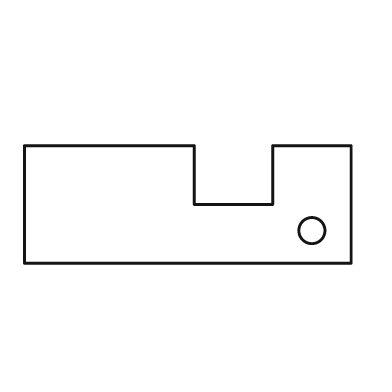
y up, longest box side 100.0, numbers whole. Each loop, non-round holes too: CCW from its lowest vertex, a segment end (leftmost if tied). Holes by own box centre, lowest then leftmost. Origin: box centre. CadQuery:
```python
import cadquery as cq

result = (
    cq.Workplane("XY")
    .moveTo(-50.0, -18.0)
    .lineTo(50.0, -18.0)
    .lineTo(50.0, 18.0)
    .lineTo(26.0, 18.0)
    .lineTo(26.0, 0.0)
    .lineTo(2.0, 0.0)
    .lineTo(2.0, 18.0)
    .lineTo(-50.0, 18.0)
    .close()
    .moveTo(38.0, -8.0)
    .circle(4.0)
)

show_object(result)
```